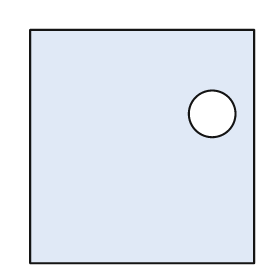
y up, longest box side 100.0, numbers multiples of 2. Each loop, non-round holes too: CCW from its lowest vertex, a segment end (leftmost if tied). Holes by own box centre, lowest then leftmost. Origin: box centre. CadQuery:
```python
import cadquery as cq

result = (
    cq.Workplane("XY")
    .moveTo(-48.0, -50.0)
    .lineTo(48.0, -50.0)
    .lineTo(48.0, 50.0)
    .lineTo(-48.0, 50.0)
    .close()
    .moveTo(30.0, 14.0)
    .circle(10.0)
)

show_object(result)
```